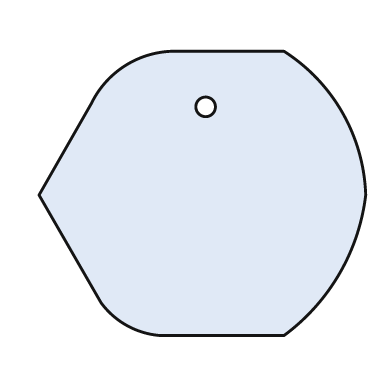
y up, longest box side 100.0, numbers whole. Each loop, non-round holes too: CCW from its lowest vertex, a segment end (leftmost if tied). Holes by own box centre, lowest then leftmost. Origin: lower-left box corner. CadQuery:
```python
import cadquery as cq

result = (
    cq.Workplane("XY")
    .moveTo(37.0, 0.0)
    .lineTo(75.0, 0.0)
    .threePointArc((92.0, 19.0), (100.0, 43.0))
    .threePointArc((93.0, 68.0), (75.0, 87.0))
    .lineTo(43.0, 87.0)
    .threePointArc((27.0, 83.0), (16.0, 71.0))
    .lineTo(0.0, 43.0)
    .lineTo(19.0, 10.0)
    .threePointArc((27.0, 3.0), (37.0, 0.0))
    .close()
    .moveTo(51.0, 70.0)
    .circle(3.0)
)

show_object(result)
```